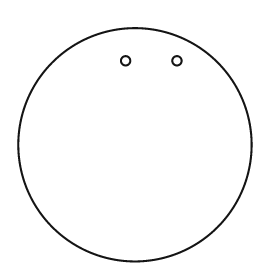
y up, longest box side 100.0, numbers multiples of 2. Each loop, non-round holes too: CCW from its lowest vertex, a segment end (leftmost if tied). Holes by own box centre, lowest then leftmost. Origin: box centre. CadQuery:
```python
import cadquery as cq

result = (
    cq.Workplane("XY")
    .moveTo(0.0, 0.0)
    .circle(50.0)
    .moveTo(-4.0, 36.0)
    .circle(2.0)
    .moveTo(18.0, 36.0)
    .circle(2.0)
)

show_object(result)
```